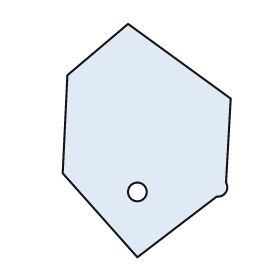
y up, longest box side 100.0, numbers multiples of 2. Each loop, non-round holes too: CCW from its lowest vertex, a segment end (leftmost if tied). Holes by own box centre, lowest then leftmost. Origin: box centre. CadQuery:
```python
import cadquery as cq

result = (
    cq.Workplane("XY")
    .moveTo(-4.0, -50.0)
    .lineTo(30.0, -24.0)
    .threePointArc((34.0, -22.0), (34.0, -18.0))
    .lineTo(36.0, 18.0)
    .lineTo(-8.0, 50.0)
    .lineTo(-34.0, 28.0)
    .lineTo(-36.0, -14.0)
    .close()
    .moveTo(-4.0, -22.0)
    .circle(4.0)
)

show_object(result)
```